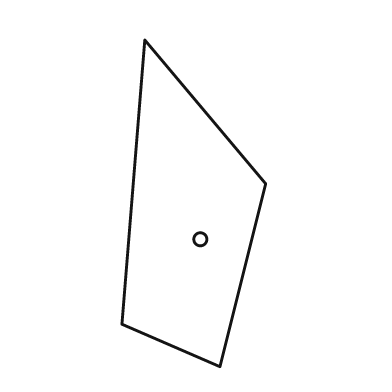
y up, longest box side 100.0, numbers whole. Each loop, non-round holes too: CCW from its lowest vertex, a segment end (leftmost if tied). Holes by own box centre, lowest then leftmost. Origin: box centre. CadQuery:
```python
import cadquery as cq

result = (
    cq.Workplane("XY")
    .moveTo(8.0, -50.0)
    .lineTo(22.0, 6.0)
    .lineTo(-15.0, 50.0)
    .lineTo(-22.0, -37.0)
    .close()
    .moveTo(2.0, -11.0)
    .circle(2.0)
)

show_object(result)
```